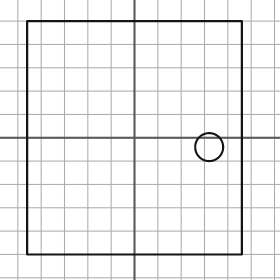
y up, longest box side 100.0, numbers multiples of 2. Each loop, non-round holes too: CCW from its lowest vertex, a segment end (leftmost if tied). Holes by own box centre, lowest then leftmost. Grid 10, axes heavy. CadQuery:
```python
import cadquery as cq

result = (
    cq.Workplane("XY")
    .moveTo(-46.0, -50.0)
    .lineTo(46.0, -50.0)
    .lineTo(46.0, 50.0)
    .lineTo(-46.0, 50.0)
    .close()
    .moveTo(32.0, -4.0)
    .circle(6.0)
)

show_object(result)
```